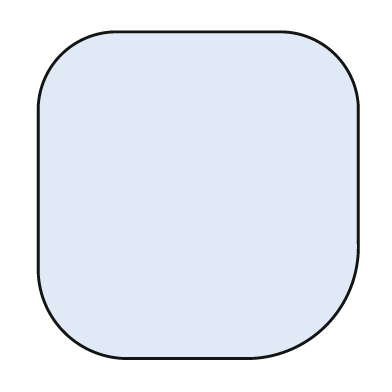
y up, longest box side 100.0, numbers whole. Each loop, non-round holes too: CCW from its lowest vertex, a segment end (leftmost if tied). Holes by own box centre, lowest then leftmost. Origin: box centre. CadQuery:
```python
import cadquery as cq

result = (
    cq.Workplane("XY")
    .moveTo(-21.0, -50.0)
    .lineTo(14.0, -50.0)
    .threePointArc((39.0, -40.0), (49.0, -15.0))
    .lineTo(49.0, 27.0)
    .threePointArc((42.0, 43.0), (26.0, 50.0))
    .lineTo(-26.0, 50.0)
    .threePointArc((-42.0, 43.0), (-49.0, 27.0))
    .lineTo(-49.0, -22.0)
    .threePointArc((-41.0, -42.0), (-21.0, -50.0))
    .close()
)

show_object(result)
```